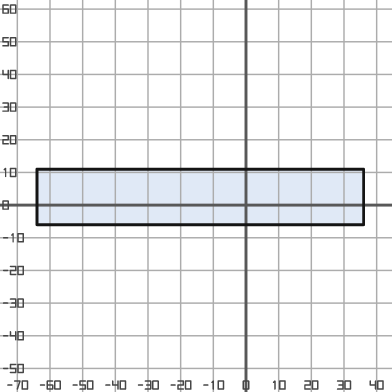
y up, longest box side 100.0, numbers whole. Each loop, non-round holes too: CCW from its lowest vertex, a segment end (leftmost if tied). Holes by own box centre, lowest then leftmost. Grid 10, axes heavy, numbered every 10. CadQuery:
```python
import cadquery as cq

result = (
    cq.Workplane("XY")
    .moveTo(-64.0, -6.0)
    .lineTo(36.0, -6.0)
    .lineTo(36.0, 11.0)
    .lineTo(-64.0, 11.0)
    .close()
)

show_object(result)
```